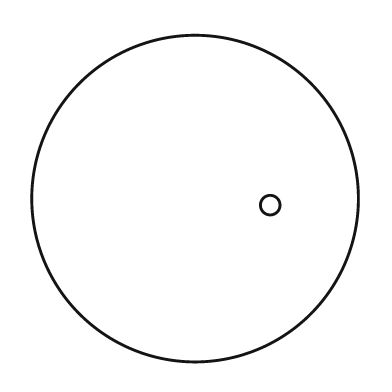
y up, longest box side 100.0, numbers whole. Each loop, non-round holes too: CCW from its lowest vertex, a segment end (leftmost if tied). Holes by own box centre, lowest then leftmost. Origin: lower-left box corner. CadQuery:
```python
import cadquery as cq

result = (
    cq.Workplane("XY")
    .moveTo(50.0, 50.0)
    .circle(50.0)
    .moveTo(73.0, 48.0)
    .circle(3.0)
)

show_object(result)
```